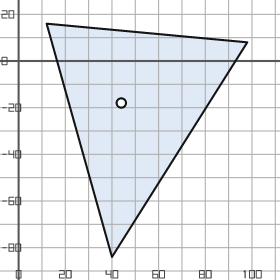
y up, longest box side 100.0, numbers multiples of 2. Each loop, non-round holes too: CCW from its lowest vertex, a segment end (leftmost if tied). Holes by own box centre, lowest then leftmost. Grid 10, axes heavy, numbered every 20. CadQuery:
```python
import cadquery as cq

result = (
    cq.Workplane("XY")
    .moveTo(40.0, -84.0)
    .lineTo(98.0, 8.0)
    .lineTo(12.0, 16.0)
    .close()
    .moveTo(44.0, -18.0)
    .circle(2.0)
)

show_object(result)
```